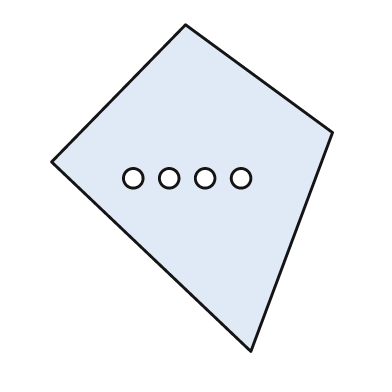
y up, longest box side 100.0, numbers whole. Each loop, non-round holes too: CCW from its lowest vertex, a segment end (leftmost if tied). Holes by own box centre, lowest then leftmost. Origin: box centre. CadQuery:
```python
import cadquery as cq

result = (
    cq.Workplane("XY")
    .moveTo(18.0, -50.0)
    .lineTo(43.0, 17.0)
    .lineTo(-2.0, 50.0)
    .lineTo(-43.0, 8.0)
    .close()
    .moveTo(-18.0, 3.0)
    .circle(3.0)
    .moveTo(-7.0, 3.0)
    .circle(3.0)
    .moveTo(4.0, 3.0)
    .circle(3.0)
    .moveTo(15.0, 3.0)
    .circle(3.0)
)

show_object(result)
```